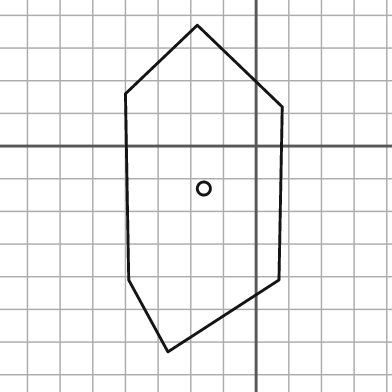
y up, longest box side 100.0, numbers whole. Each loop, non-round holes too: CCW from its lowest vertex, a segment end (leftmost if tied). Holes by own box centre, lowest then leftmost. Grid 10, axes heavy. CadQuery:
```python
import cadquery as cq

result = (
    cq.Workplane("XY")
    .moveTo(-27.0, -63.0)
    .lineTo(7.0, -41.0)
    .lineTo(8.0, 12.0)
    .lineTo(-18.0, 37.0)
    .lineTo(-40.0, 16.0)
    .lineTo(-39.0, -41.0)
    .close()
    .moveTo(-16.0, -13.0)
    .circle(2.0)
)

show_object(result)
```